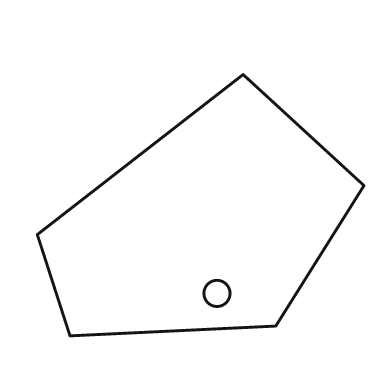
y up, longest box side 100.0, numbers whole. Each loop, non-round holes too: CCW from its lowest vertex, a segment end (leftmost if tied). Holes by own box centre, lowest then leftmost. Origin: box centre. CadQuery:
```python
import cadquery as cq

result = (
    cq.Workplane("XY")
    .moveTo(-40.0, -40.0)
    .lineTo(23.0, -37.0)
    .lineTo(50.0, 6.0)
    .lineTo(13.0, 40.0)
    .lineTo(-50.0, -9.0)
    .close()
    .moveTo(5.0, -27.0)
    .circle(4.0)
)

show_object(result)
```